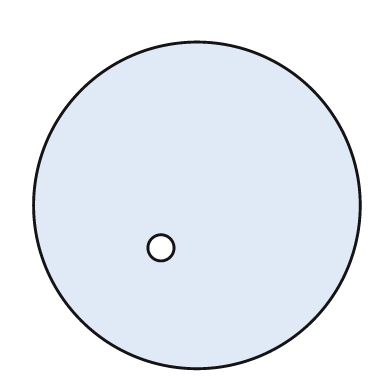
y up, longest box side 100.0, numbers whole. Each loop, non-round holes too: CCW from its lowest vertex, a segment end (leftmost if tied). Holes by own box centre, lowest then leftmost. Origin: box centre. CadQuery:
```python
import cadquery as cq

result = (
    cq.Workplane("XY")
    .moveTo(0.0, 0.0)
    .circle(50.0)
    .moveTo(-11.0, -13.0)
    .circle(4.0)
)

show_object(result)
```